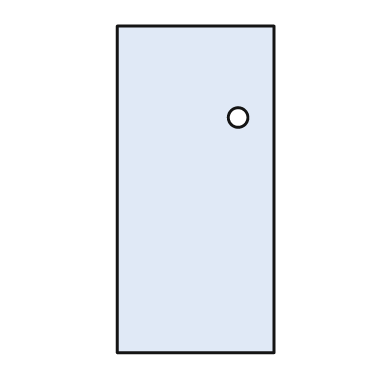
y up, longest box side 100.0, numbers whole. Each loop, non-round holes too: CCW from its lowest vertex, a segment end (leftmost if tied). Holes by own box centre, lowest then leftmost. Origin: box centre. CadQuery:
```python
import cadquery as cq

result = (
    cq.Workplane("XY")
    .moveTo(-24.0, -50.0)
    .lineTo(24.0, -50.0)
    .lineTo(24.0, 50.0)
    .lineTo(-24.0, 50.0)
    .close()
    .moveTo(13.0, 22.0)
    .circle(3.0)
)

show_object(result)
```